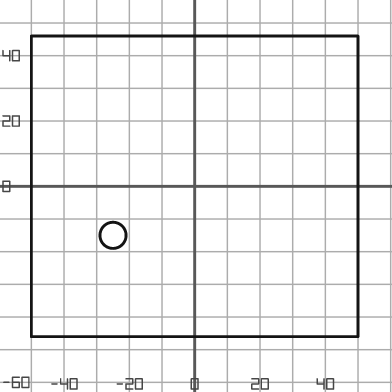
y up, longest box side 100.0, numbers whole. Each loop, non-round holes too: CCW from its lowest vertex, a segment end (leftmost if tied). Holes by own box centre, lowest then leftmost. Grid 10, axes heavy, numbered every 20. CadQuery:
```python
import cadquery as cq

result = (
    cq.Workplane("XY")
    .moveTo(-50.0, -46.0)
    .lineTo(50.0, -46.0)
    .lineTo(50.0, 46.0)
    .lineTo(-50.0, 46.0)
    .close()
    .moveTo(-25.0, -15.0)
    .circle(4.0)
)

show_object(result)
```